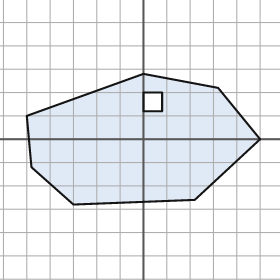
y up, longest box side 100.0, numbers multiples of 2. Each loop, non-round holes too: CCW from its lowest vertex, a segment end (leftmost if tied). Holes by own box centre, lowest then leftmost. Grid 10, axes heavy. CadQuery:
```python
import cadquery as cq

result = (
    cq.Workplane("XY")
    .moveTo(-30.0, -28.0)
    .lineTo(22.0, -26.0)
    .lineTo(50.0, 0.0)
    .lineTo(32.0, 22.0)
    .lineTo(0.0, 28.0)
    .lineTo(-50.0, 10.0)
    .lineTo(-48.0, -12.0)
    .close()
    .moveTo(0.0, 12.0)
    .lineTo(8.0, 12.0)
    .lineTo(8.0, 20.0)
    .lineTo(0.0, 20.0)
    .close()
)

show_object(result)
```